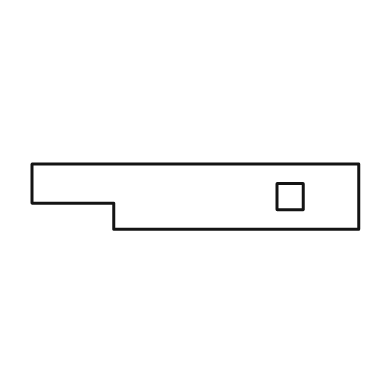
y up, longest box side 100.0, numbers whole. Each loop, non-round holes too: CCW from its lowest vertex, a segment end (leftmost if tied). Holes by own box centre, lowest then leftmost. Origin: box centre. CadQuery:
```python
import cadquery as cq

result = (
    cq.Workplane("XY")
    .moveTo(-25.0, -10.0)
    .lineTo(50.0, -10.0)
    .lineTo(50.0, 10.0)
    .lineTo(-50.0, 10.0)
    .lineTo(-50.0, -2.0)
    .lineTo(-25.0, -2.0)
    .close()
    .moveTo(25.0, -4.0)
    .lineTo(33.0, -4.0)
    .lineTo(33.0, 4.0)
    .lineTo(25.0, 4.0)
    .close()
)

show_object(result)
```